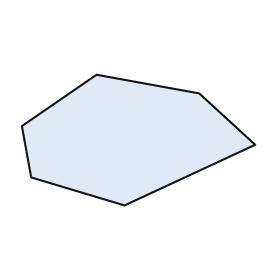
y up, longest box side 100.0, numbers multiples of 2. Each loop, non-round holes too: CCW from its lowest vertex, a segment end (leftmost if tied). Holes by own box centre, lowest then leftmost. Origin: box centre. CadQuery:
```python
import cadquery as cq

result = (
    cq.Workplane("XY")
    .moveTo(-6.0, -28.0)
    .lineTo(50.0, -2.0)
    .lineTo(26.0, 20.0)
    .lineTo(-18.0, 28.0)
    .lineTo(-50.0, 6.0)
    .lineTo(-46.0, -16.0)
    .close()
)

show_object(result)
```